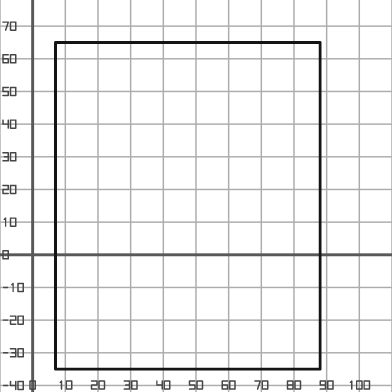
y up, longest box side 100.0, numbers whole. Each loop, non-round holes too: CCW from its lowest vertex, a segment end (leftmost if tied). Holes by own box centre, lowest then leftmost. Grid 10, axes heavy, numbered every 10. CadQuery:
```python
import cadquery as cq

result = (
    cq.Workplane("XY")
    .moveTo(7.0, -35.0)
    .lineTo(88.0, -35.0)
    .lineTo(88.0, 65.0)
    .lineTo(7.0, 65.0)
    .close()
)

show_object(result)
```